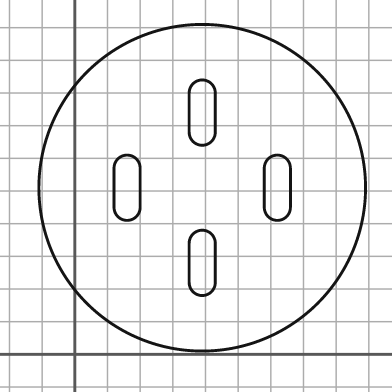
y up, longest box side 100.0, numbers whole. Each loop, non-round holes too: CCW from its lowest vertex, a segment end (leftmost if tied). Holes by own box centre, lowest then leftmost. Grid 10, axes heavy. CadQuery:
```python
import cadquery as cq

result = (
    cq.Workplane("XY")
    .moveTo(39.0, 51.0)
    .circle(50.0)
    .moveTo(35.0, 22.0)
    .threePointArc((39.0, 18.0), (43.0, 22.0))
    .lineTo(43.0, 34.0)
    .threePointArc((39.0, 38.0), (35.0, 34.0))
    .close()
    .moveTo(12.0, 45.0)
    .threePointArc((16.0, 41.0), (20.0, 45.0))
    .lineTo(20.0, 57.0)
    .threePointArc((16.0, 61.0), (12.0, 57.0))
    .close()
    .moveTo(58.0, 45.0)
    .threePointArc((62.0, 41.0), (66.0, 45.0))
    .lineTo(66.0, 57.0)
    .threePointArc((62.0, 61.0), (58.0, 57.0))
    .close()
    .moveTo(35.0, 68.0)
    .threePointArc((39.0, 64.0), (43.0, 68.0))
    .lineTo(43.0, 80.0)
    .threePointArc((39.0, 84.0), (35.0, 80.0))
    .close()
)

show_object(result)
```